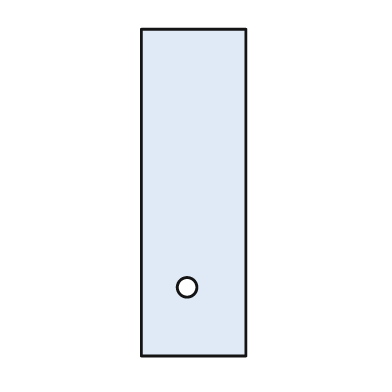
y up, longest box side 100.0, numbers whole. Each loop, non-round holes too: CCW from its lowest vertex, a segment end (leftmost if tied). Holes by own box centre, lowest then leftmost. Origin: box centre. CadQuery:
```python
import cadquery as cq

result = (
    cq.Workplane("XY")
    .moveTo(-16.0, -50.0)
    .lineTo(16.0, -50.0)
    .lineTo(16.0, 50.0)
    .lineTo(-16.0, 50.0)
    .close()
    .moveTo(-2.0, -29.0)
    .circle(3.0)
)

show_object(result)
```